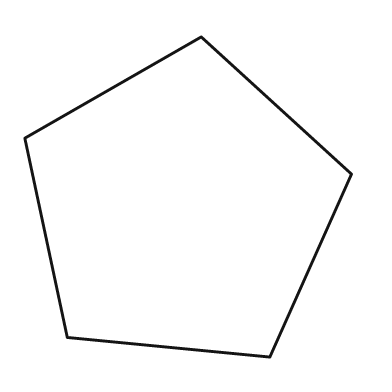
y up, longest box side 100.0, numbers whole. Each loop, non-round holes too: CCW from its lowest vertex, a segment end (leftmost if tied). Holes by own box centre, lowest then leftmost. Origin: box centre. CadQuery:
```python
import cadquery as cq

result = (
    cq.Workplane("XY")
    .moveTo(25.0, -49.0)
    .lineTo(50.0, 7.0)
    .lineTo(4.0, 49.0)
    .lineTo(-50.0, 18.0)
    .lineTo(-37.0, -43.0)
    .close()
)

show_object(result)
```